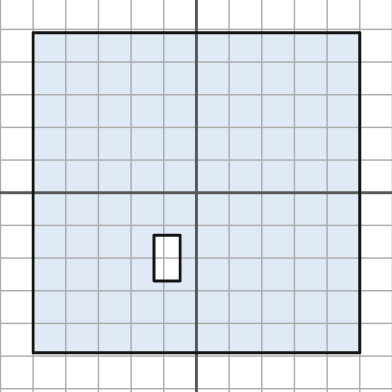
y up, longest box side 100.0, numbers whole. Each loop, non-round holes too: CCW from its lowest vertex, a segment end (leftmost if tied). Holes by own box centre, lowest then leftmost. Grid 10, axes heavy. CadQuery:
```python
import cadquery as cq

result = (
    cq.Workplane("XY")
    .moveTo(-50.0, -49.0)
    .lineTo(50.0, -49.0)
    .lineTo(50.0, 49.0)
    .lineTo(-50.0, 49.0)
    .close()
    .moveTo(-13.0, -27.0)
    .lineTo(-5.0, -27.0)
    .lineTo(-5.0, -13.0)
    .lineTo(-13.0, -13.0)
    .close()
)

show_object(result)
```